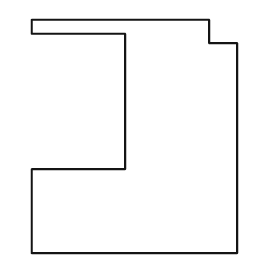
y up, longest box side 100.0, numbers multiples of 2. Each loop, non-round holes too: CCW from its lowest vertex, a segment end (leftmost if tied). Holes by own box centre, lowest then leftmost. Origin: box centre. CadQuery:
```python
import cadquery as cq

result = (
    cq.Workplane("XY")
    .moveTo(-44.0, -50.0)
    .lineTo(44.0, -50.0)
    .lineTo(44.0, 40.0)
    .lineTo(32.0, 40.0)
    .lineTo(32.0, 50.0)
    .lineTo(-44.0, 50.0)
    .lineTo(-44.0, 44.0)
    .lineTo(-4.0, 44.0)
    .lineTo(-4.0, -14.0)
    .lineTo(-44.0, -14.0)
    .close()
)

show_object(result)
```